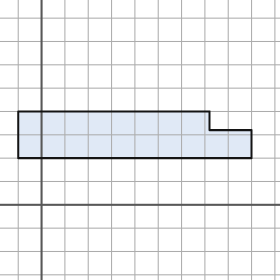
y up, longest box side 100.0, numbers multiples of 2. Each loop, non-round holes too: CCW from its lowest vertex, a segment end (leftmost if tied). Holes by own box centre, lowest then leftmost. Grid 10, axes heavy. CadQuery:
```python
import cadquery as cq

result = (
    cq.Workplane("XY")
    .moveTo(-10.0, 20.0)
    .lineTo(90.0, 20.0)
    .lineTo(90.0, 32.0)
    .lineTo(72.0, 32.0)
    .lineTo(72.0, 40.0)
    .lineTo(-10.0, 40.0)
    .close()
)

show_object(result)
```